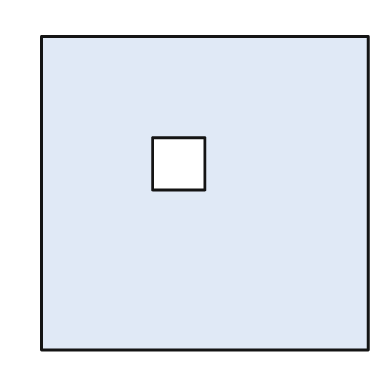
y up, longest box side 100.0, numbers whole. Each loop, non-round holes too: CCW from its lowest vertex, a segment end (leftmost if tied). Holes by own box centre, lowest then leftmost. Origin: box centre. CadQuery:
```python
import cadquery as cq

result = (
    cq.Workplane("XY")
    .moveTo(-50.0, -48.0)
    .lineTo(50.0, -48.0)
    .lineTo(50.0, 48.0)
    .lineTo(-50.0, 48.0)
    .close()
    .moveTo(-16.0, 1.0)
    .lineTo(0.0, 1.0)
    .lineTo(0.0, 17.0)
    .lineTo(-16.0, 17.0)
    .close()
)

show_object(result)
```